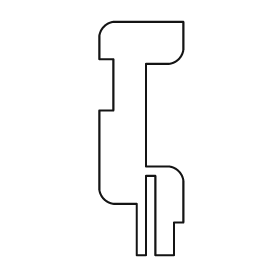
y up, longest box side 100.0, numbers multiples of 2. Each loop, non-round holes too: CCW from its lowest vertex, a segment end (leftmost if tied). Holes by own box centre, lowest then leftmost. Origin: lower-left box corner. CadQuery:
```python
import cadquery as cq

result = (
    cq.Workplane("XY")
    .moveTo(16.0, 0.0)
    .lineTo(20.0, 0.0)
    .lineTo(20.0, 34.0)
    .lineTo(24.0, 34.0)
    .lineTo(24.0, 0.0)
    .lineTo(32.0, 0.0)
    .lineTo(32.0, 14.0)
    .lineTo(36.0, 14.0)
    .lineTo(36.0, 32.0)
    .threePointArc((34.0, 36.0), (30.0, 38.0))
    .lineTo(20.0, 38.0)
    .lineTo(20.0, 82.0)
    .lineTo(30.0, 82.0)
    .threePointArc((34.0, 84.0), (36.0, 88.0))
    .lineTo(36.0, 100.0)
    .lineTo(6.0, 100.0)
    .threePointArc((2.0, 98.0), (0.0, 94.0))
    .lineTo(0.0, 84.0)
    .lineTo(6.0, 84.0)
    .lineTo(6.0, 62.0)
    .lineTo(0.0, 62.0)
    .lineTo(0.0, 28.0)
    .threePointArc((2.0, 24.0), (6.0, 22.0))
    .lineTo(16.0, 22.0)
    .close()
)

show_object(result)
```